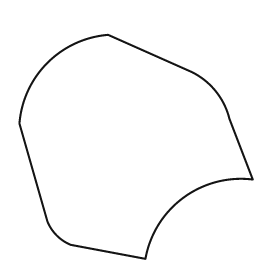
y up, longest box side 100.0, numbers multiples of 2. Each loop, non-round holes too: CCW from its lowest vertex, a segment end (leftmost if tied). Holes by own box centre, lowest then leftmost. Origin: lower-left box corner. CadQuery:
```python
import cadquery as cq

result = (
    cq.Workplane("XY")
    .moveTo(54.0, 0.0)
    .threePointArc((70.0, 26.0), (100.0, 34.0))
    .lineTo(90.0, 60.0)
    .threePointArc((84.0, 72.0), (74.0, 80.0))
    .lineTo(38.0, 96.0)
    .threePointArc((12.0, 84.0), (0.0, 58.0))
    .lineTo(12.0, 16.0)
    .threePointArc((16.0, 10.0), (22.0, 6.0))
    .close()
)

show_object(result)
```